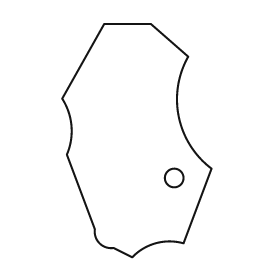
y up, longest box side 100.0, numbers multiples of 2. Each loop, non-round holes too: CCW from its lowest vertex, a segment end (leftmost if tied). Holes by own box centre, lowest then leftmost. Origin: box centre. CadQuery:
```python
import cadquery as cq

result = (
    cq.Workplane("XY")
    .moveTo(-2.0, -50.0)
    .threePointArc((8.0, -44.0), (20.0, -44.0))
    .lineTo(32.0, -12.0)
    .threePointArc((18.0, 10.0), (22.0, 36.0))
    .lineTo(6.0, 50.0)
    .lineTo(-14.0, 50.0)
    .lineTo(-32.0, 18.0)
    .threePointArc((-28.0, 6.0), (-30.0, -6.0))
    .lineTo(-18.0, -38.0)
    .threePointArc((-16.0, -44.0), (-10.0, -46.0))
    .close()
    .moveTo(16.0, -16.0)
    .circle(4.0)
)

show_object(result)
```